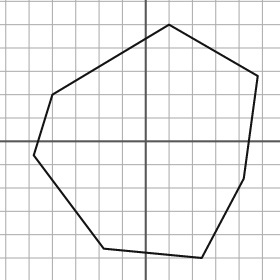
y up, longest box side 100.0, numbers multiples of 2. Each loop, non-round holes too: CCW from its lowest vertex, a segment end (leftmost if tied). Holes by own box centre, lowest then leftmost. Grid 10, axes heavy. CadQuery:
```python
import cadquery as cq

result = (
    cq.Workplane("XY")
    .moveTo(24.0, -50.0)
    .lineTo(42.0, -16.0)
    .lineTo(48.0, 28.0)
    .lineTo(10.0, 50.0)
    .lineTo(-40.0, 20.0)
    .lineTo(-48.0, -6.0)
    .lineTo(-18.0, -46.0)
    .close()
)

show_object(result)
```